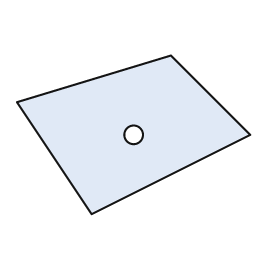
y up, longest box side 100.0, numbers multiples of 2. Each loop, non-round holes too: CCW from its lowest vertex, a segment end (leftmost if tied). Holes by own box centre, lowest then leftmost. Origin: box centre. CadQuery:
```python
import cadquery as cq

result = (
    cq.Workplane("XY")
    .moveTo(-18.0, -34.0)
    .lineTo(50.0, 0.0)
    .lineTo(16.0, 34.0)
    .lineTo(-50.0, 14.0)
    .close()
    .moveTo(0.0, 0.0)
    .circle(4.0)
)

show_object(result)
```